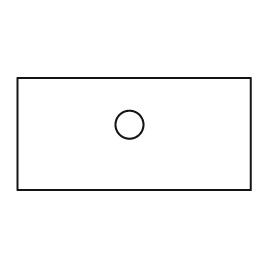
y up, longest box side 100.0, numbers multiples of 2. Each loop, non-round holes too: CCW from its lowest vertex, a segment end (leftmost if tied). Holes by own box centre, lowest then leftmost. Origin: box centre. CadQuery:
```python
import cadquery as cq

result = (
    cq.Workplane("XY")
    .moveTo(-50.0, -24.0)
    .lineTo(50.0, -24.0)
    .lineTo(50.0, 24.0)
    .lineTo(-50.0, 24.0)
    .close()
    .moveTo(-2.0, 4.0)
    .circle(6.0)
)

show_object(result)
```